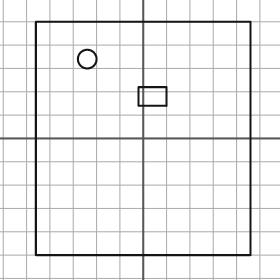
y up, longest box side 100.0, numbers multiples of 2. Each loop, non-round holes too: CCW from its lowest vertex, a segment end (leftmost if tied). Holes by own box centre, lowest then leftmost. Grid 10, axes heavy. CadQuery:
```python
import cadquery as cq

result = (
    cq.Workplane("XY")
    .moveTo(-46.0, -50.0)
    .lineTo(46.0, -50.0)
    .lineTo(46.0, 50.0)
    .lineTo(-46.0, 50.0)
    .close()
    .moveTo(-2.0, 14.0)
    .lineTo(10.0, 14.0)
    .lineTo(10.0, 22.0)
    .lineTo(-2.0, 22.0)
    .close()
    .moveTo(-24.0, 34.0)
    .circle(4.0)
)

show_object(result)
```